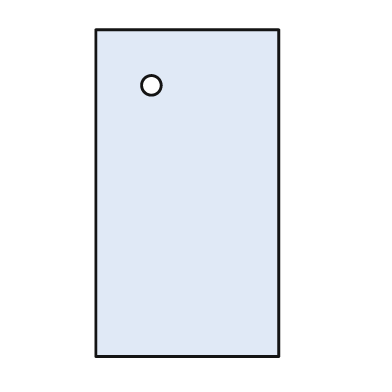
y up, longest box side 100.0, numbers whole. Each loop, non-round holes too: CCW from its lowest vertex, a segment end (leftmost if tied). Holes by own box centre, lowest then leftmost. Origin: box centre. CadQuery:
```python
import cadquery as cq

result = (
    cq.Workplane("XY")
    .moveTo(-28.0, -50.0)
    .lineTo(28.0, -50.0)
    .lineTo(28.0, 50.0)
    .lineTo(-28.0, 50.0)
    .close()
    .moveTo(-11.0, 33.0)
    .circle(3.0)
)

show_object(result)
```